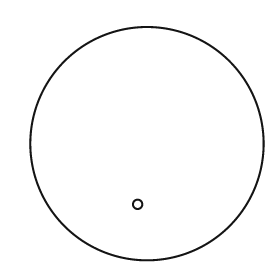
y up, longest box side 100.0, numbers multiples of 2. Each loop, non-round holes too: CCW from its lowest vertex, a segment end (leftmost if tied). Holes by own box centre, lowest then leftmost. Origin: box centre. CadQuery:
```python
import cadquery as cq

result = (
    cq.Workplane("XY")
    .moveTo(0.0, 0.0)
    .circle(50.0)
    .moveTo(-4.0, -26.0)
    .circle(2.0)
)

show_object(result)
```